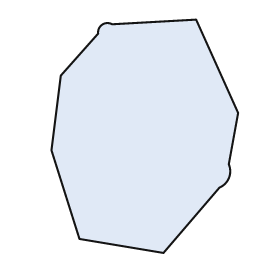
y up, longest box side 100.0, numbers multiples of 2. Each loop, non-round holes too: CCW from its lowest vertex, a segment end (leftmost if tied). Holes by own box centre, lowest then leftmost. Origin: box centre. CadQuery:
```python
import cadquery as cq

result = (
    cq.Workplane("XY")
    .moveTo(8.0, -50.0)
    .lineTo(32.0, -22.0)
    .threePointArc((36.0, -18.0), (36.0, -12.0))
    .lineTo(40.0, 10.0)
    .lineTo(22.0, 50.0)
    .lineTo(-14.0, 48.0)
    .threePointArc((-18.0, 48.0), (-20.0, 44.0))
    .lineTo(-36.0, 26.0)
    .lineTo(-40.0, -6.0)
    .lineTo(-28.0, -44.0)
    .close()
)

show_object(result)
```